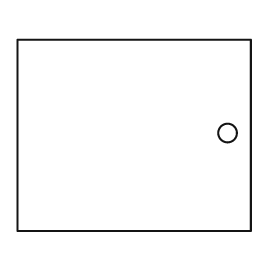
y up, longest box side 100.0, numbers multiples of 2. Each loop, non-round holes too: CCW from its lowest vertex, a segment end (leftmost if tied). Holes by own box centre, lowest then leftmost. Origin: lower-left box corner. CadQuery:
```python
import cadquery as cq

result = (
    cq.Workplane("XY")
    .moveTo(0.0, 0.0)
    .lineTo(100.0, 0.0)
    .lineTo(100.0, 82.0)
    .lineTo(0.0, 82.0)
    .close()
    .moveTo(90.0, 42.0)
    .circle(4.0)
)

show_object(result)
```